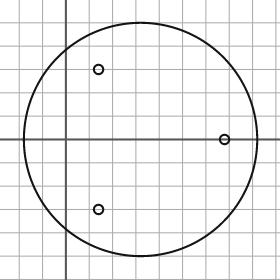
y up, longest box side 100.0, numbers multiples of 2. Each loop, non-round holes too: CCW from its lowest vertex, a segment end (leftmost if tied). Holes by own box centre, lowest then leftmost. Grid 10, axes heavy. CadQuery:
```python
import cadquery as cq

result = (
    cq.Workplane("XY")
    .moveTo(32.0, 0.0)
    .circle(50.0)
    .moveTo(14.0, -30.0)
    .circle(2.0)
    .moveTo(68.0, 0.0)
    .circle(2.0)
    .moveTo(14.0, 30.0)
    .circle(2.0)
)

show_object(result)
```